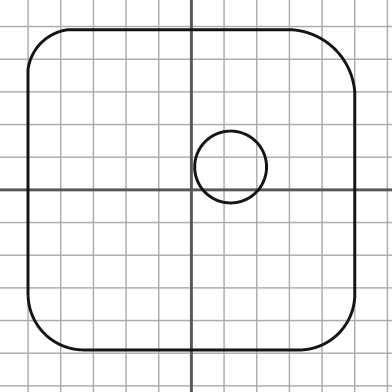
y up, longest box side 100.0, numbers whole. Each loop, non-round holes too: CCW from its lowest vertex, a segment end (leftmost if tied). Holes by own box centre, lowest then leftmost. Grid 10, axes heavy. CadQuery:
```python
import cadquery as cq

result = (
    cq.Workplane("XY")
    .moveTo(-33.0, -49.0)
    .lineTo(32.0, -49.0)
    .threePointArc((45.0, -44.0), (50.0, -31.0))
    .lineTo(50.0, 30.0)
    .threePointArc((44.0, 43.0), (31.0, 49.0))
    .lineTo(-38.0, 49.0)
    .threePointArc((-46.0, 45.0), (-50.0, 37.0))
    .lineTo(-50.0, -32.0)
    .threePointArc((-45.0, -44.0), (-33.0, -49.0))
    .close()
    .moveTo(12.0, 7.0)
    .circle(11.0)
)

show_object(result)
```